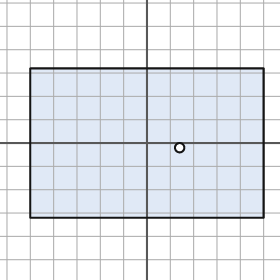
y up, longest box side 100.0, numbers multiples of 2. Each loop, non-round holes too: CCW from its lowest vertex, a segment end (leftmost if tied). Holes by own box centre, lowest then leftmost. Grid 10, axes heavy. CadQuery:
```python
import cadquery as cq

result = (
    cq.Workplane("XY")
    .moveTo(-50.0, -32.0)
    .lineTo(50.0, -32.0)
    .lineTo(50.0, 32.0)
    .lineTo(-50.0, 32.0)
    .close()
    .moveTo(14.0, -2.0)
    .circle(2.0)
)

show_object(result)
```